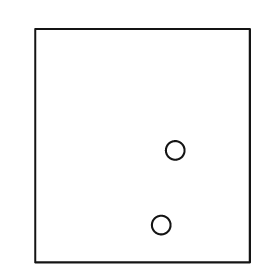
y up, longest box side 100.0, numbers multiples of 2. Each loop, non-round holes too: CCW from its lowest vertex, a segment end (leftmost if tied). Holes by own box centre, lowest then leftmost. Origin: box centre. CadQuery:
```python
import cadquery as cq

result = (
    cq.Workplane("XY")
    .moveTo(-46.0, -50.0)
    .lineTo(46.0, -50.0)
    .lineTo(46.0, 50.0)
    .lineTo(-46.0, 50.0)
    .close()
    .moveTo(8.0, -34.0)
    .circle(4.0)
    .moveTo(14.0, -2.0)
    .circle(4.0)
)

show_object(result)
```